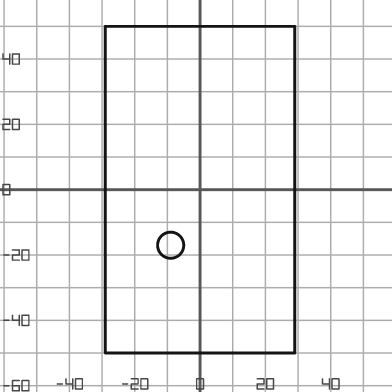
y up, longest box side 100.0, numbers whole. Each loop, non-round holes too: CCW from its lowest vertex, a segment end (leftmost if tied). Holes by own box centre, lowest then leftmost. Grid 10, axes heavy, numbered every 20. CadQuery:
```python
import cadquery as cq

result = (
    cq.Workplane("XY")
    .moveTo(-29.0, -50.0)
    .lineTo(29.0, -50.0)
    .lineTo(29.0, 50.0)
    .lineTo(-29.0, 50.0)
    .close()
    .moveTo(-9.0, -17.0)
    .circle(4.0)
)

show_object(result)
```